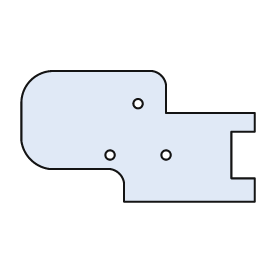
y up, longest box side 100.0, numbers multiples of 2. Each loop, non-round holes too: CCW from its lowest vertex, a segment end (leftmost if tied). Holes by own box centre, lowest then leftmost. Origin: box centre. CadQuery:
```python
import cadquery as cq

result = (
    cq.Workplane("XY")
    .moveTo(-6.0, -28.0)
    .lineTo(50.0, -28.0)
    .lineTo(50.0, -18.0)
    .lineTo(40.0, -18.0)
    .lineTo(40.0, 2.0)
    .lineTo(50.0, 2.0)
    .lineTo(50.0, 10.0)
    .lineTo(12.0, 10.0)
    .lineTo(12.0, 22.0)
    .threePointArc((10.0, 26.0), (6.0, 28.0))
    .lineTo(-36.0, 28.0)
    .threePointArc((-46.0, 24.0), (-50.0, 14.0))
    .lineTo(-50.0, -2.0)
    .threePointArc((-46.0, -10.0), (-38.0, -14.0))
    .lineTo(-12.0, -14.0)
    .threePointArc((-8.0, -16.0), (-6.0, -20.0))
    .close()
    .moveTo(-12.0, -8.0)
    .circle(2.0)
    .moveTo(12.0, -8.0)
    .circle(2.0)
    .moveTo(0.0, 14.0)
    .circle(2.0)
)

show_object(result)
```